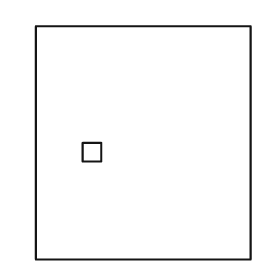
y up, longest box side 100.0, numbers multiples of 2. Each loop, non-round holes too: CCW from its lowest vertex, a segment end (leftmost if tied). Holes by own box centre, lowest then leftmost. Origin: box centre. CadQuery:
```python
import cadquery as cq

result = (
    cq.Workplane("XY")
    .moveTo(-46.0, -50.0)
    .lineTo(46.0, -50.0)
    .lineTo(46.0, 50.0)
    .lineTo(-46.0, 50.0)
    .close()
    .moveTo(-26.0, -8.0)
    .lineTo(-18.0, -8.0)
    .lineTo(-18.0, 0.0)
    .lineTo(-26.0, 0.0)
    .close()
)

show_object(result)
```